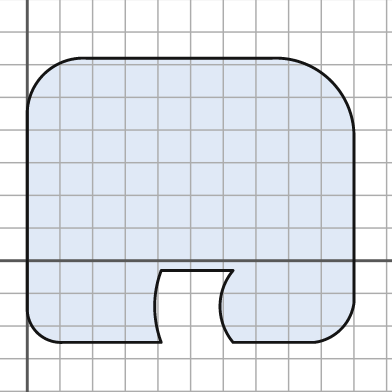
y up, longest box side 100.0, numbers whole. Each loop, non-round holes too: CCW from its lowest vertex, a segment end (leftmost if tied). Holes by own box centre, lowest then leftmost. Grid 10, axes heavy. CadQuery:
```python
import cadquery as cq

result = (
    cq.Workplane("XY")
    .moveTo(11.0, -25.0)
    .lineTo(41.0, -25.0)
    .threePointArc((39.0, -14.0), (41.0, -3.0))
    .lineTo(63.0, -3.0)
    .threePointArc((59.0, -14.0), (63.0, -25.0))
    .lineTo(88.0, -25.0)
    .threePointArc((96.0, -21.0), (100.0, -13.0))
    .lineTo(100.0, 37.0)
    .threePointArc((93.0, 55.0), (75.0, 62.0))
    .lineTo(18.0, 62.0)
    .threePointArc((5.0, 57.0), (0.0, 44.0))
    .lineTo(0.0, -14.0)
    .threePointArc((3.0, -22.0), (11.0, -25.0))
    .close()
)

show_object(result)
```